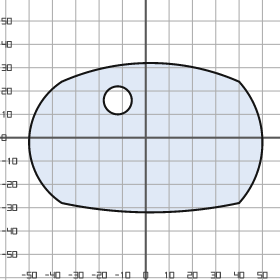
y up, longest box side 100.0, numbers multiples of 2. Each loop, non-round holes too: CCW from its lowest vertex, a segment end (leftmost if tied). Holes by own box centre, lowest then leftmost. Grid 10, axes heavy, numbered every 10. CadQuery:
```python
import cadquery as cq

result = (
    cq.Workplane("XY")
    .moveTo(-36.0, -28.0)
    .threePointArc((2.0, -32.0), (40.0, -28.0))
    .threePointArc((50.0, -2.0), (40.0, 24.0))
    .threePointArc((2.0, 32.0), (-36.0, 24.0))
    .threePointArc((-50.0, -2.0), (-36.0, -28.0))
    .close()
    .moveTo(-12.0, 16.0)
    .circle(6.0)
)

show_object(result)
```